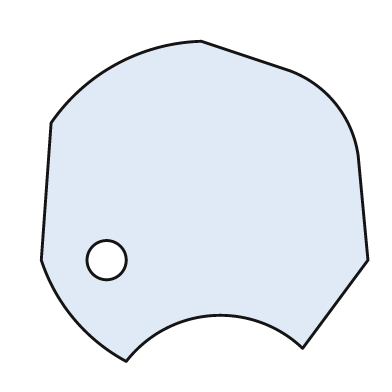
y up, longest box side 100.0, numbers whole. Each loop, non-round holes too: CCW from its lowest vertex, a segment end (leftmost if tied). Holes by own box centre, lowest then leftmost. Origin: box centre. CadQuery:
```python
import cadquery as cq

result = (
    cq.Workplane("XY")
    .moveTo(-24.0, -49.0)
    .threePointArc((2.0, -35.0), (30.0, -45.0))
    .lineTo(50.0, -18.0)
    .lineTo(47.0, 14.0)
    .threePointArc((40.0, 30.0), (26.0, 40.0))
    .lineTo(-1.0, 49.0)
    .threePointArc((-27.0, 42.0), (-47.0, 24.0))
    .lineTo(-50.0, -18.0)
    .threePointArc((-40.0, -36.0), (-24.0, -49.0))
    .close()
    .moveTo(-30.0, -18.0)
    .circle(6.0)
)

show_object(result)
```